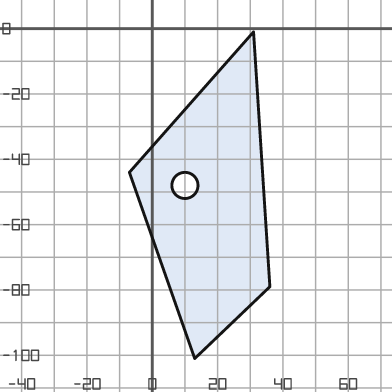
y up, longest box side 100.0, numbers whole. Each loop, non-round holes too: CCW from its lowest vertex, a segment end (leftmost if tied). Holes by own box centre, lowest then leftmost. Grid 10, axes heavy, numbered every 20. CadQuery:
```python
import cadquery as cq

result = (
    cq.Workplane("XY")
    .moveTo(13.0, -101.0)
    .lineTo(36.0, -79.0)
    .lineTo(31.0, -1.0)
    .lineTo(-7.0, -44.0)
    .close()
    .moveTo(10.0, -48.0)
    .circle(4.0)
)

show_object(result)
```